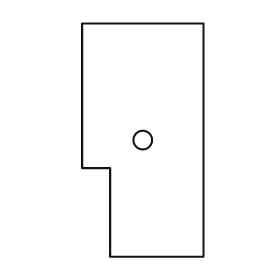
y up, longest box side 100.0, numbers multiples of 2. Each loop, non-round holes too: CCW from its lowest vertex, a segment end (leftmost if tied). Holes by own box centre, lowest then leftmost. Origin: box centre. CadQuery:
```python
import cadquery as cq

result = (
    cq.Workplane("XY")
    .moveTo(-14.0, -50.0)
    .lineTo(26.0, -50.0)
    .lineTo(26.0, 50.0)
    .lineTo(-26.0, 50.0)
    .lineTo(-26.0, -12.0)
    .lineTo(-14.0, -12.0)
    .close()
    .moveTo(0.0, 0.0)
    .circle(4.0)
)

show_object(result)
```